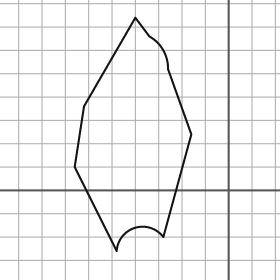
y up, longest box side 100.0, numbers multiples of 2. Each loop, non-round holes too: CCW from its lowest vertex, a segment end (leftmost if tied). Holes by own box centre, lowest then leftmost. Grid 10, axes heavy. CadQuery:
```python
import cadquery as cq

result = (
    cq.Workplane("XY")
    .moveTo(-48.0, -26.0)
    .threePointArc((-40.0, -16.0), (-28.0, -20.0))
    .lineTo(-16.0, 24.0)
    .lineTo(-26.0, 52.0)
    .threePointArc((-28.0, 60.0), (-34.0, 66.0))
    .lineTo(-40.0, 74.0)
    .lineTo(-62.0, 36.0)
    .lineTo(-66.0, 10.0)
    .close()
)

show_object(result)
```